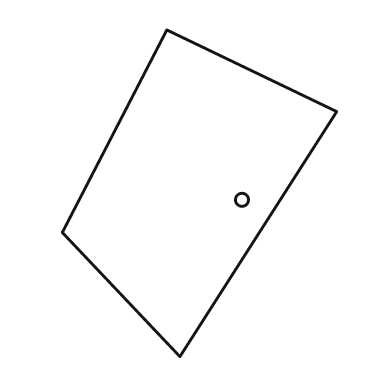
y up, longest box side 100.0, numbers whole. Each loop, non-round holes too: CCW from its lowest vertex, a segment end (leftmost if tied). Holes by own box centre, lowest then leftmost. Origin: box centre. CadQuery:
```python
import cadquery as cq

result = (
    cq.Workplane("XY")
    .moveTo(-6.0, -50.0)
    .lineTo(42.0, 25.0)
    .lineTo(-10.0, 50.0)
    .lineTo(-42.0, -12.0)
    .close()
    .moveTo(13.0, -2.0)
    .circle(2.0)
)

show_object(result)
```